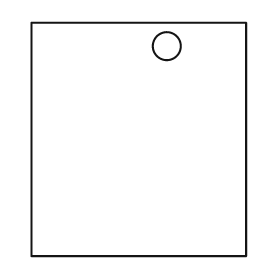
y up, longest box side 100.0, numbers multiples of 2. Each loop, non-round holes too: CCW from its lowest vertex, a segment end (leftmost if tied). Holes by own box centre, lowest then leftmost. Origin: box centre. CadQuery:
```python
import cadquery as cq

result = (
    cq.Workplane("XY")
    .moveTo(-46.0, -50.0)
    .lineTo(46.0, -50.0)
    .lineTo(46.0, 50.0)
    .lineTo(-46.0, 50.0)
    .close()
    .moveTo(12.0, 40.0)
    .circle(6.0)
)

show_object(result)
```